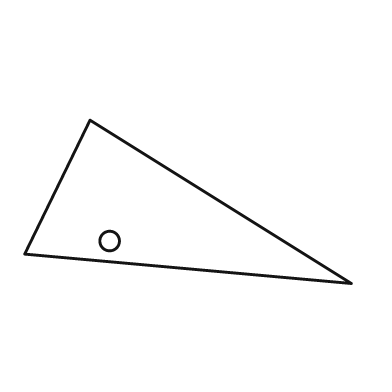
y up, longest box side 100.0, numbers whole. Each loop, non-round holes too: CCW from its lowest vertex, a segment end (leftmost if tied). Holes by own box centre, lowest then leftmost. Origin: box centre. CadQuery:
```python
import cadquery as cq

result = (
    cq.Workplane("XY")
    .moveTo(50.0, -25.0)
    .lineTo(-30.0, 25.0)
    .lineTo(-50.0, -16.0)
    .close()
    .moveTo(-24.0, -12.0)
    .circle(3.0)
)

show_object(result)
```